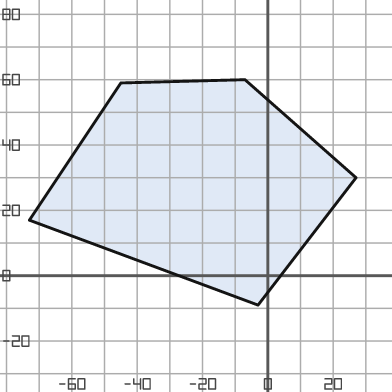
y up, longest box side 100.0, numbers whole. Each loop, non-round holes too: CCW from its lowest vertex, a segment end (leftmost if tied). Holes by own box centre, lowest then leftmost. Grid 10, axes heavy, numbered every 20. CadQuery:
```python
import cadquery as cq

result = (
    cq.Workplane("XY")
    .moveTo(-3.0, -9.0)
    .lineTo(27.0, 30.0)
    .lineTo(-7.0, 60.0)
    .lineTo(-45.0, 59.0)
    .lineTo(-73.0, 17.0)
    .close()
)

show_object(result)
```